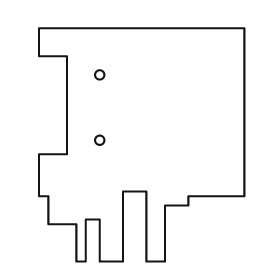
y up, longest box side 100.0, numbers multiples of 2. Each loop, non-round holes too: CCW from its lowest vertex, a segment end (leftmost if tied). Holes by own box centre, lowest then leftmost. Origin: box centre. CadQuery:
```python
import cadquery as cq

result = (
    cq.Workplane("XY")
    .moveTo(-28.0, -50.0)
    .lineTo(-24.0, -50.0)
    .lineTo(-24.0, -32.0)
    .lineTo(-18.0, -32.0)
    .lineTo(-18.0, -50.0)
    .lineTo(-8.0, -50.0)
    .lineTo(-8.0, -20.0)
    .lineTo(2.0, -20.0)
    .lineTo(2.0, -50.0)
    .lineTo(10.0, -50.0)
    .lineTo(10.0, -26.0)
    .lineTo(20.0, -26.0)
    .lineTo(20.0, -22.0)
    .lineTo(44.0, -22.0)
    .lineTo(44.0, 50.0)
    .lineTo(-44.0, 50.0)
    .lineTo(-44.0, 38.0)
    .lineTo(-32.0, 38.0)
    .lineTo(-32.0, -4.0)
    .lineTo(-44.0, -4.0)
    .lineTo(-44.0, -22.0)
    .lineTo(-40.0, -22.0)
    .lineTo(-40.0, -34.0)
    .lineTo(-28.0, -34.0)
    .close()
    .moveTo(-18.0, 2.0)
    .circle(2.0)
    .moveTo(-18.0, 30.0)
    .circle(2.0)
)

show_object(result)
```